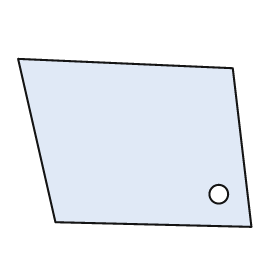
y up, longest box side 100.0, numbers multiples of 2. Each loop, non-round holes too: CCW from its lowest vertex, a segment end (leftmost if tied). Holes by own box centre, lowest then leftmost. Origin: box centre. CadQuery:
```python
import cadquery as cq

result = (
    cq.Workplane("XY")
    .moveTo(50.0, -36.0)
    .lineTo(42.0, 32.0)
    .lineTo(-50.0, 36.0)
    .lineTo(-34.0, -34.0)
    .close()
    .moveTo(36.0, -22.0)
    .circle(4.0)
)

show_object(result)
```